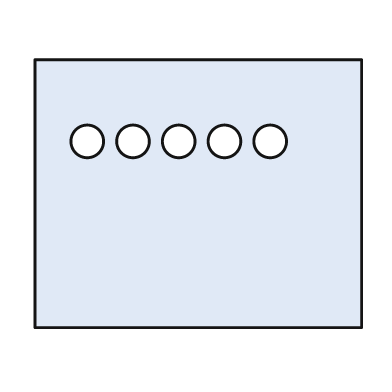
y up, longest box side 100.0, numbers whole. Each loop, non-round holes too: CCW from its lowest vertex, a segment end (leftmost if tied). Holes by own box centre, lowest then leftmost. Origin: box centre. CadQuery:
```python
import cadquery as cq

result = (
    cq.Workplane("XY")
    .moveTo(-50.0, -41.0)
    .lineTo(50.0, -41.0)
    .lineTo(50.0, 41.0)
    .lineTo(-50.0, 41.0)
    .close()
    .moveTo(-34.0, 16.0)
    .circle(5.0)
    .moveTo(-20.0, 16.0)
    .circle(5.0)
    .moveTo(-6.0, 16.0)
    .circle(5.0)
    .moveTo(8.0, 16.0)
    .circle(5.0)
    .moveTo(22.0, 16.0)
    .circle(5.0)
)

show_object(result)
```